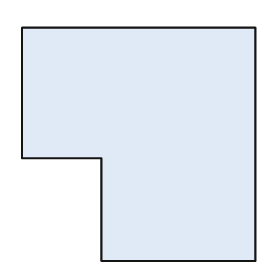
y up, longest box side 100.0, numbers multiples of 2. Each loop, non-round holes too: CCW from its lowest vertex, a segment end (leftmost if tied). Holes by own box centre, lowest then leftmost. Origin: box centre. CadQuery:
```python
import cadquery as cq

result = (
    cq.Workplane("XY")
    .moveTo(-16.0, -50.0)
    .lineTo(50.0, -50.0)
    .lineTo(50.0, 50.0)
    .lineTo(-50.0, 50.0)
    .lineTo(-50.0, -6.0)
    .lineTo(-16.0, -6.0)
    .close()
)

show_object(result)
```